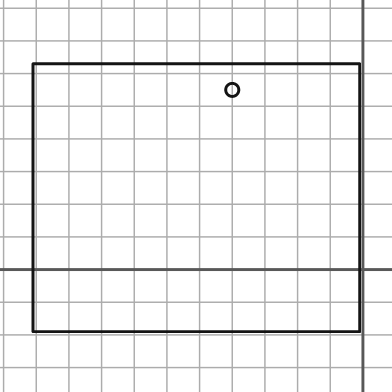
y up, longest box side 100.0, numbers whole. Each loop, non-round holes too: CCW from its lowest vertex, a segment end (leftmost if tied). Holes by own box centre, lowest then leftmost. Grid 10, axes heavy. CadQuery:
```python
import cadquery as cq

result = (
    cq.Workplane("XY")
    .moveTo(-101.0, -19.0)
    .lineTo(-1.0, -19.0)
    .lineTo(-1.0, 63.0)
    .lineTo(-101.0, 63.0)
    .close()
    .moveTo(-40.0, 55.0)
    .circle(2.0)
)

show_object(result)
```